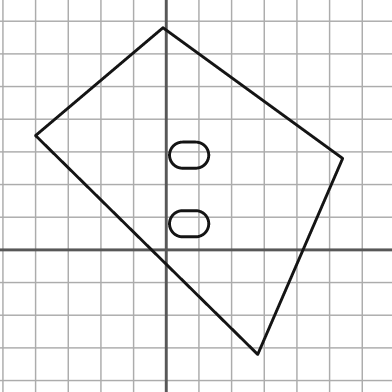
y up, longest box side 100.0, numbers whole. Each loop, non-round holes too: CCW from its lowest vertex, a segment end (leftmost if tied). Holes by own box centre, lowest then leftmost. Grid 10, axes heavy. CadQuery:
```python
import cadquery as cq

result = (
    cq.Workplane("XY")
    .moveTo(28.0, -32.0)
    .lineTo(54.0, 28.0)
    .lineTo(-1.0, 68.0)
    .lineTo(-40.0, 35.0)
    .close()
    .moveTo(5.0, 4.0)
    .lineTo(9.0, 4.0)
    .threePointArc((13.0, 8.0), (9.0, 12.0))
    .lineTo(5.0, 12.0)
    .threePointArc((1.0, 8.0), (5.0, 4.0))
    .close()
    .moveTo(5.0, 25.0)
    .lineTo(9.0, 25.0)
    .threePointArc((13.0, 29.0), (9.0, 33.0))
    .lineTo(5.0, 33.0)
    .threePointArc((1.0, 29.0), (5.0, 25.0))
    .close()
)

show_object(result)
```